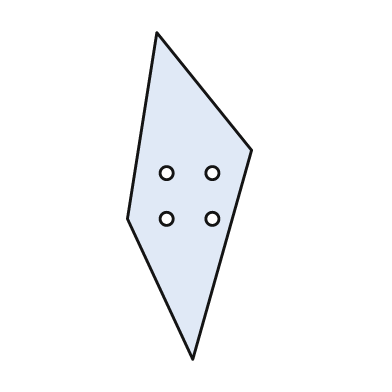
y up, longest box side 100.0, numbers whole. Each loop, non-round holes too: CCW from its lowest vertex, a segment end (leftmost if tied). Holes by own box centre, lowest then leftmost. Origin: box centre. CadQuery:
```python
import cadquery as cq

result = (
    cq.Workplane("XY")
    .moveTo(1.0, -50.0)
    .lineTo(19.0, 14.0)
    .lineTo(-10.0, 50.0)
    .lineTo(-19.0, -7.0)
    .close()
    .moveTo(-7.0, -7.0)
    .circle(2.0)
    .moveTo(7.0, -7.0)
    .circle(2.0)
    .moveTo(-7.0, 7.0)
    .circle(2.0)
    .moveTo(7.0, 7.0)
    .circle(2.0)
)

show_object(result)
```